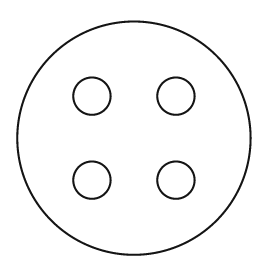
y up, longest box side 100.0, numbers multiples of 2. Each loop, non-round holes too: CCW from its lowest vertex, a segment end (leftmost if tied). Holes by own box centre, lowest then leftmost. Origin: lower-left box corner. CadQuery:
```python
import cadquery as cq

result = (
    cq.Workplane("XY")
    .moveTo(50.0, 50.0)
    .circle(50.0)
    .moveTo(32.0, 32.0)
    .circle(8.0)
    .moveTo(68.0, 32.0)
    .circle(8.0)
    .moveTo(32.0, 68.0)
    .circle(8.0)
    .moveTo(68.0, 68.0)
    .circle(8.0)
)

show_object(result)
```